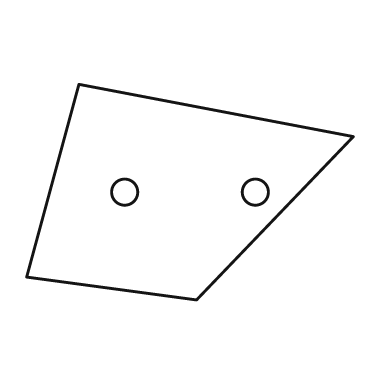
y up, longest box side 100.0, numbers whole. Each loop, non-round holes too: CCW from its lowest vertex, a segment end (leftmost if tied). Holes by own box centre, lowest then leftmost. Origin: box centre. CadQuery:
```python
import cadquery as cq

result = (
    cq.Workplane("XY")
    .moveTo(2.0, -33.0)
    .lineTo(50.0, 17.0)
    .lineTo(-34.0, 33.0)
    .lineTo(-50.0, -26.0)
    .close()
    .moveTo(-20.0, 0.0)
    .circle(4.0)
    .moveTo(20.0, 0.0)
    .circle(4.0)
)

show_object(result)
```